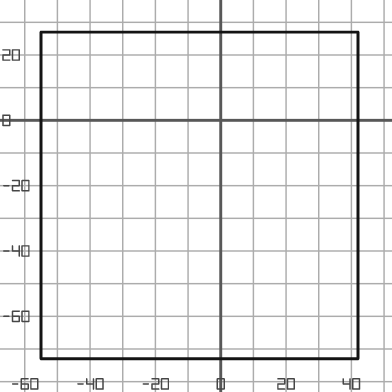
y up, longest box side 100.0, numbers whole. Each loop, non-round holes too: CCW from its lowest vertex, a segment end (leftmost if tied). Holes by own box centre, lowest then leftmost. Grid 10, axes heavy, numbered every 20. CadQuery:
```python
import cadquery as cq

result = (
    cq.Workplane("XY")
    .moveTo(-55.0, -73.0)
    .lineTo(42.0, -73.0)
    .lineTo(42.0, 27.0)
    .lineTo(-55.0, 27.0)
    .close()
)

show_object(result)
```